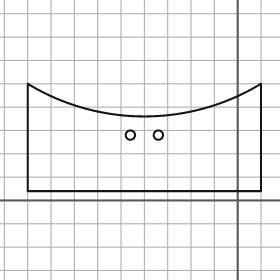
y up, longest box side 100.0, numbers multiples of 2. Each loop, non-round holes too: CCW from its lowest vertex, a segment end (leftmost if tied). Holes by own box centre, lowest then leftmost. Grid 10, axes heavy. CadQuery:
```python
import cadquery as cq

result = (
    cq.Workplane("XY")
    .moveTo(-90.0, 4.0)
    .lineTo(10.0, 4.0)
    .lineTo(10.0, 50.0)
    .threePointArc((-40.0, 36.0), (-90.0, 50.0))
    .close()
    .moveTo(-46.0, 28.0)
    .circle(2.0)
    .moveTo(-34.0, 28.0)
    .circle(2.0)
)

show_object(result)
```